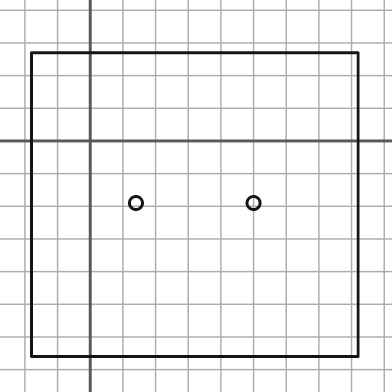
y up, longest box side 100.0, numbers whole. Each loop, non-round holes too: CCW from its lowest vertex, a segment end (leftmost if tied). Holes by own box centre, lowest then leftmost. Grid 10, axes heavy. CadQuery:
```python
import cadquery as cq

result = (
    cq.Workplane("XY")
    .moveTo(-18.0, -66.0)
    .lineTo(82.0, -66.0)
    .lineTo(82.0, 27.0)
    .lineTo(-18.0, 27.0)
    .close()
    .moveTo(14.0, -19.0)
    .circle(2.0)
    .moveTo(50.0, -19.0)
    .circle(2.0)
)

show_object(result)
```